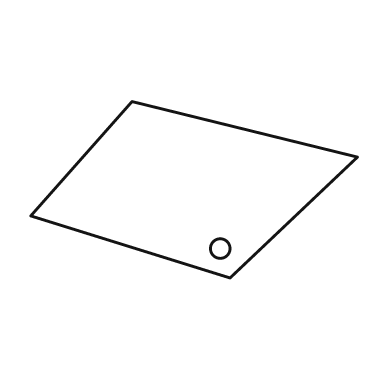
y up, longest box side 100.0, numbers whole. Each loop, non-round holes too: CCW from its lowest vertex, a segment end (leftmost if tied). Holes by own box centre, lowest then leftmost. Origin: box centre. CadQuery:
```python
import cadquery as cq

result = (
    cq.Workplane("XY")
    .moveTo(11.0, -27.0)
    .lineTo(50.0, 10.0)
    .lineTo(-19.0, 27.0)
    .lineTo(-50.0, -8.0)
    .close()
    .moveTo(8.0, -18.0)
    .circle(3.0)
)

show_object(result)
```